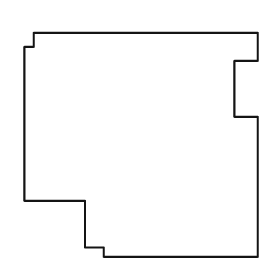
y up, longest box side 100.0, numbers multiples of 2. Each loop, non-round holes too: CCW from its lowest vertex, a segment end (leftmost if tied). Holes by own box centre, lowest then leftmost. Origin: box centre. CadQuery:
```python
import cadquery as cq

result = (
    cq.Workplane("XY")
    .moveTo(-16.0, -48.0)
    .lineTo(50.0, -48.0)
    .lineTo(50.0, 12.0)
    .lineTo(40.0, 12.0)
    .lineTo(40.0, 36.0)
    .lineTo(50.0, 36.0)
    .lineTo(50.0, 48.0)
    .lineTo(-46.0, 48.0)
    .lineTo(-46.0, 42.0)
    .lineTo(-50.0, 42.0)
    .lineTo(-50.0, -24.0)
    .lineTo(-24.0, -24.0)
    .lineTo(-24.0, -44.0)
    .lineTo(-16.0, -44.0)
    .close()
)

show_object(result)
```